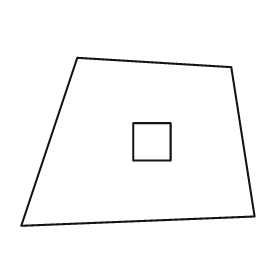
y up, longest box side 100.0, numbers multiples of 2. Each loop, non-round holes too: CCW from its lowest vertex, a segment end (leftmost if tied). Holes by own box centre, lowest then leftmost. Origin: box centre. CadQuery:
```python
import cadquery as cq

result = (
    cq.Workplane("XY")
    .moveTo(-50.0, -36.0)
    .lineTo(50.0, -32.0)
    .lineTo(40.0, 32.0)
    .lineTo(-26.0, 36.0)
    .close()
    .moveTo(-2.0, -8.0)
    .lineTo(14.0, -8.0)
    .lineTo(14.0, 8.0)
    .lineTo(-2.0, 8.0)
    .close()
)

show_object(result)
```